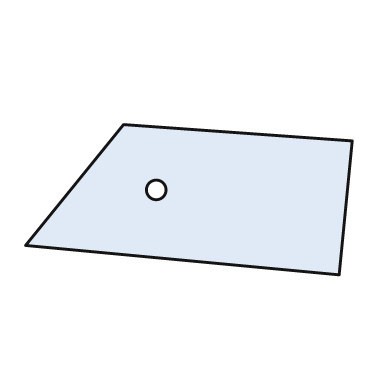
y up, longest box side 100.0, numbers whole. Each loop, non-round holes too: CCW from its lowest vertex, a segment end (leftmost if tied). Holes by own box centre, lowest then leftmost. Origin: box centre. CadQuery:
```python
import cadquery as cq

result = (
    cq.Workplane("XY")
    .moveTo(46.0, -23.0)
    .lineTo(50.0, 18.0)
    .lineTo(-20.0, 23.0)
    .lineTo(-50.0, -14.0)
    .close()
    .moveTo(-10.0, 3.0)
    .circle(3.0)
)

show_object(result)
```